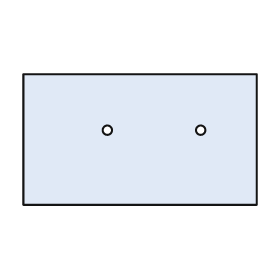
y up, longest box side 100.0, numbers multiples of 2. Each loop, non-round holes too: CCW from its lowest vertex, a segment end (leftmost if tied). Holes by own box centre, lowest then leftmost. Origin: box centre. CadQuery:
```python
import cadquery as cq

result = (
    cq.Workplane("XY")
    .moveTo(-50.0, -28.0)
    .lineTo(50.0, -28.0)
    .lineTo(50.0, 28.0)
    .lineTo(-50.0, 28.0)
    .close()
    .moveTo(-14.0, 4.0)
    .circle(2.0)
    .moveTo(26.0, 4.0)
    .circle(2.0)
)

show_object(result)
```